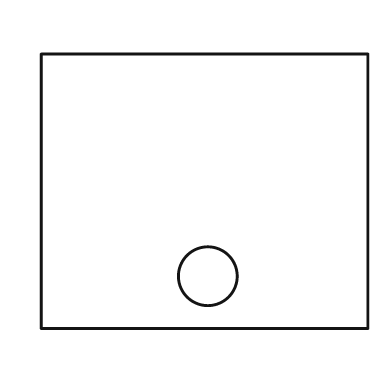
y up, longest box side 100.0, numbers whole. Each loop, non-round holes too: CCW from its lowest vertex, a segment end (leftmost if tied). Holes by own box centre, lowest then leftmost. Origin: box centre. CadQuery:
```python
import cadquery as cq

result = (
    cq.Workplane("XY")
    .moveTo(-50.0, -42.0)
    .lineTo(50.0, -42.0)
    .lineTo(50.0, 42.0)
    .lineTo(-50.0, 42.0)
    .close()
    .moveTo(1.0, -26.0)
    .circle(9.0)
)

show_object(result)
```